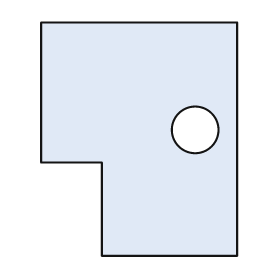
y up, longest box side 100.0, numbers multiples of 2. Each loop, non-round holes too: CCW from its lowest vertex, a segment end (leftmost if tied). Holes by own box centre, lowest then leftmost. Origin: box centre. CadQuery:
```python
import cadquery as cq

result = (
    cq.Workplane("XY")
    .moveTo(-16.0, -50.0)
    .lineTo(42.0, -50.0)
    .lineTo(42.0, 50.0)
    .lineTo(-42.0, 50.0)
    .lineTo(-42.0, -10.0)
    .lineTo(-16.0, -10.0)
    .close()
    .moveTo(24.0, 4.0)
    .circle(10.0)
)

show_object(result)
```